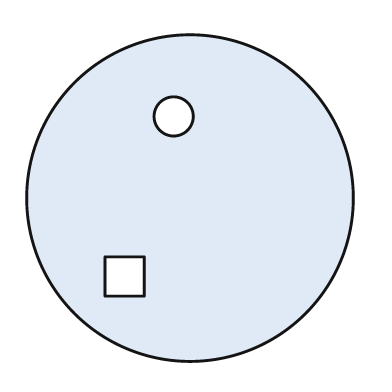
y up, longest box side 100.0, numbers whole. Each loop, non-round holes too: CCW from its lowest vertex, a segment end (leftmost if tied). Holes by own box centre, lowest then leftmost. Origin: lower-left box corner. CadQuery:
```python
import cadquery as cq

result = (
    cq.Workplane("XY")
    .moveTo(50.0, 50.0)
    .circle(50.0)
    .moveTo(24.0, 20.0)
    .lineTo(36.0, 20.0)
    .lineTo(36.0, 32.0)
    .lineTo(24.0, 32.0)
    .close()
    .moveTo(45.0, 75.0)
    .circle(6.0)
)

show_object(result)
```